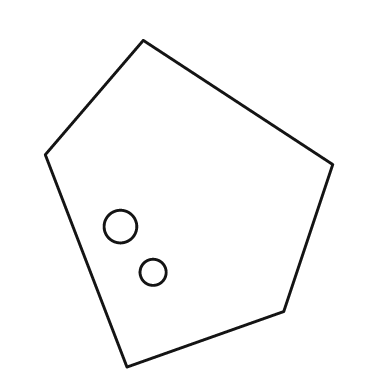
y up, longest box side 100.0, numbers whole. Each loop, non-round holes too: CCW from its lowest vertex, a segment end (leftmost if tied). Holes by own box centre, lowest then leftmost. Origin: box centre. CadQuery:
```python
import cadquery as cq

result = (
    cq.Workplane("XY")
    .moveTo(-19.0, -50.0)
    .lineTo(29.0, -33.0)
    .lineTo(44.0, 12.0)
    .lineTo(-14.0, 50.0)
    .lineTo(-44.0, 15.0)
    .close()
    .moveTo(-11.0, -21.0)
    .circle(4.0)
    .moveTo(-21.0, -7.0)
    .circle(5.0)
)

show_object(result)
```